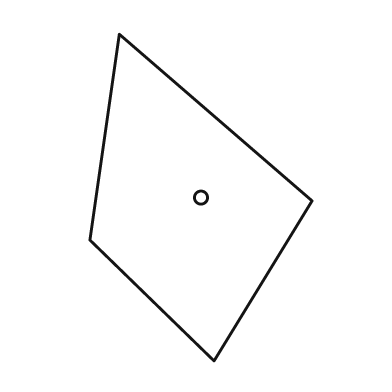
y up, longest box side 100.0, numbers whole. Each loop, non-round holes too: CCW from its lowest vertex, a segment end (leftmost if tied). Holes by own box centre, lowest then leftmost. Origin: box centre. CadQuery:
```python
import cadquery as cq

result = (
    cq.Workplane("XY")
    .moveTo(4.0, -50.0)
    .lineTo(34.0, -1.0)
    .lineTo(-25.0, 50.0)
    .lineTo(-34.0, -13.0)
    .close()
    .moveTo(0.0, 0.0)
    .circle(2.0)
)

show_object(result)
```